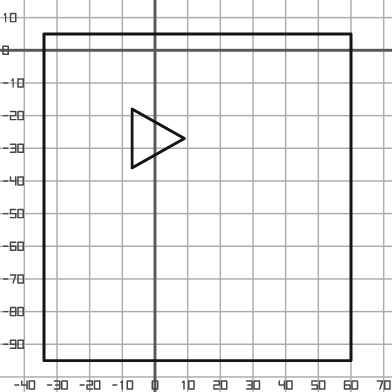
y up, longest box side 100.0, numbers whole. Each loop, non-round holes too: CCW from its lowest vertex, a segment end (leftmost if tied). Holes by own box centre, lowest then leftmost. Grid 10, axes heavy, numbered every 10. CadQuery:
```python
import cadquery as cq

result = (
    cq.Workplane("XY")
    .moveTo(-34.0, -95.0)
    .lineTo(60.0, -95.0)
    .lineTo(60.0, 5.0)
    .lineTo(-34.0, 5.0)
    .close()
    .moveTo(-7.0, -36.0)
    .lineTo(9.0, -27.0)
    .lineTo(-7.0, -18.0)
    .close()
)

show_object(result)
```